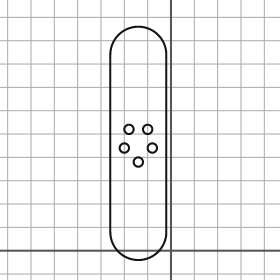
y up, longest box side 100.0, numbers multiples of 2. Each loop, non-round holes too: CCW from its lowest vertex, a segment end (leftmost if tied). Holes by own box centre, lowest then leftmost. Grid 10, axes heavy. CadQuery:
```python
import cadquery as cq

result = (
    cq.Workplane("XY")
    .moveTo(-26.0, 8.0)
    .threePointArc((-14.0, -4.0), (-2.0, 8.0))
    .lineTo(-2.0, 84.0)
    .threePointArc((-14.0, 96.0), (-26.0, 84.0))
    .close()
    .moveTo(-14.0, 38.0)
    .circle(2.0)
    .moveTo(-20.0, 44.0)
    .circle(2.0)
    .moveTo(-8.0, 44.0)
    .circle(2.0)
    .moveTo(-18.0, 52.0)
    .circle(2.0)
    .moveTo(-10.0, 52.0)
    .circle(2.0)
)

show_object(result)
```